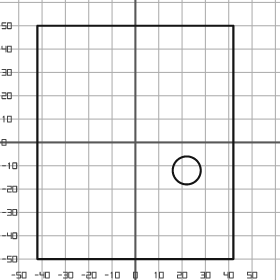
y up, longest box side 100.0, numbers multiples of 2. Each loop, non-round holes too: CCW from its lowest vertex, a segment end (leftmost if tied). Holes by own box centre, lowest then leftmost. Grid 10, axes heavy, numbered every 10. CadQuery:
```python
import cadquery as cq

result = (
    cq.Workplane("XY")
    .moveTo(-42.0, -50.0)
    .lineTo(42.0, -50.0)
    .lineTo(42.0, 50.0)
    .lineTo(-42.0, 50.0)
    .close()
    .moveTo(22.0, -12.0)
    .circle(6.0)
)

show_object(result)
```